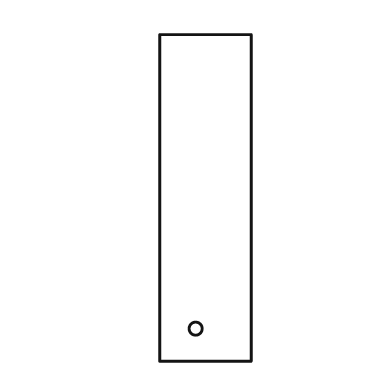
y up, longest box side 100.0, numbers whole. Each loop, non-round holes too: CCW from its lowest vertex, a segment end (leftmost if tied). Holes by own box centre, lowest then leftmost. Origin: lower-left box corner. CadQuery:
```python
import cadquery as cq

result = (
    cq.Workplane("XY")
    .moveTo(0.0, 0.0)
    .lineTo(28.0, 0.0)
    .lineTo(28.0, 100.0)
    .lineTo(0.0, 100.0)
    .close()
    .moveTo(11.0, 10.0)
    .circle(2.0)
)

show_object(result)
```